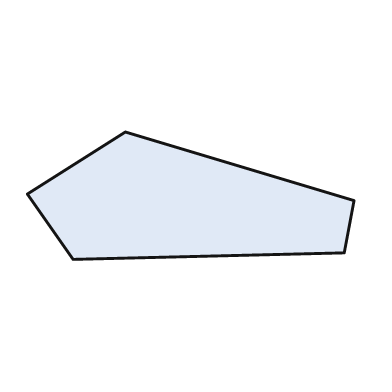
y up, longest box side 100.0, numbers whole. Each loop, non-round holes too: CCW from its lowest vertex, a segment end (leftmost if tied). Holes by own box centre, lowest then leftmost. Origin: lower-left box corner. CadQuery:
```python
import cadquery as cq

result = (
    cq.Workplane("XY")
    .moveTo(14.0, 0.0)
    .lineTo(97.0, 2.0)
    .lineTo(100.0, 18.0)
    .lineTo(30.0, 39.0)
    .lineTo(0.0, 20.0)
    .close()
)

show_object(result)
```